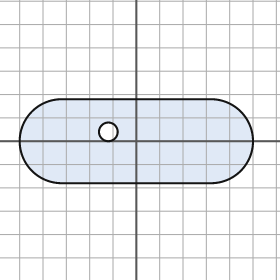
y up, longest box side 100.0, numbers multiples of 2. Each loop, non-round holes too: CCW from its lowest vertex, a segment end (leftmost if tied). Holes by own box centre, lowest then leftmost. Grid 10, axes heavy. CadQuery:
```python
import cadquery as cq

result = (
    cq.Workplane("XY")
    .moveTo(-32.0, -18.0)
    .lineTo(32.0, -18.0)
    .threePointArc((50.0, 0.0), (32.0, 18.0))
    .lineTo(-32.0, 18.0)
    .threePointArc((-50.0, 0.0), (-32.0, -18.0))
    .close()
    .moveTo(-12.0, 4.0)
    .circle(4.0)
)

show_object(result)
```